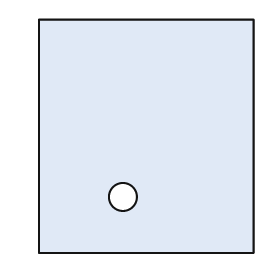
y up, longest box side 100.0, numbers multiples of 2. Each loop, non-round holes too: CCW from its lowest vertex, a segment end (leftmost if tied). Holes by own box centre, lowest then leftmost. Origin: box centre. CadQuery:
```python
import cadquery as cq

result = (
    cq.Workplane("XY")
    .moveTo(-46.0, -50.0)
    .lineTo(46.0, -50.0)
    .lineTo(46.0, 50.0)
    .lineTo(-46.0, 50.0)
    .close()
    .moveTo(-10.0, -26.0)
    .circle(6.0)
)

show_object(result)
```